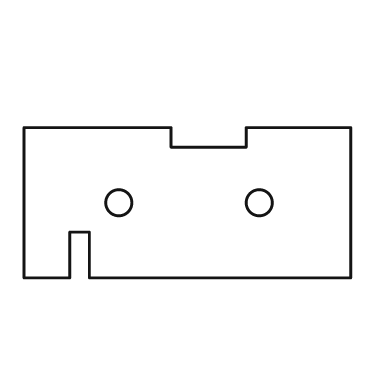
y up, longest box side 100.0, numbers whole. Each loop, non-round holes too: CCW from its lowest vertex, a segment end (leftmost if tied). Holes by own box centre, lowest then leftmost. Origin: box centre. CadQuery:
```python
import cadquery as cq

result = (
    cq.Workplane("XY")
    .moveTo(-50.0, -23.0)
    .lineTo(-36.0, -23.0)
    .lineTo(-36.0, -9.0)
    .lineTo(-30.0, -9.0)
    .lineTo(-30.0, -23.0)
    .lineTo(50.0, -23.0)
    .lineTo(50.0, 23.0)
    .lineTo(18.0, 23.0)
    .lineTo(18.0, 17.0)
    .lineTo(-5.0, 17.0)
    .lineTo(-5.0, 23.0)
    .lineTo(-50.0, 23.0)
    .close()
    .moveTo(-21.0, 0.0)
    .circle(4.0)
    .moveTo(22.0, 0.0)
    .circle(4.0)
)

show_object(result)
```